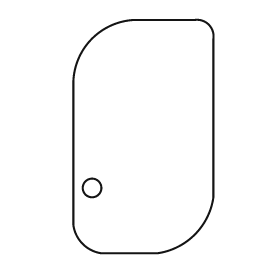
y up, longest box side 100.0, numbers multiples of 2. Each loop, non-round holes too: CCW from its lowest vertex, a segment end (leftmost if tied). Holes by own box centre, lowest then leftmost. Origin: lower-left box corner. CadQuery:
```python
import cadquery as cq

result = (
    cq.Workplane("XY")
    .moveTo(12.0, 0.0)
    .lineTo(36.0, 0.0)
    .threePointArc((52.0, 8.0), (60.0, 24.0))
    .lineTo(60.0, 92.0)
    .threePointArc((58.0, 98.0), (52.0, 100.0))
    .lineTo(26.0, 100.0)
    .threePointArc((8.0, 92.0), (0.0, 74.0))
    .lineTo(0.0, 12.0)
    .threePointArc((4.0, 4.0), (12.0, 0.0))
    .close()
    .moveTo(8.0, 28.0)
    .circle(4.0)
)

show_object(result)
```